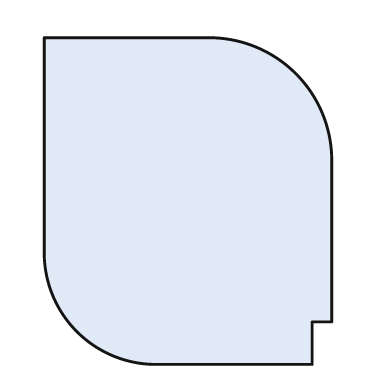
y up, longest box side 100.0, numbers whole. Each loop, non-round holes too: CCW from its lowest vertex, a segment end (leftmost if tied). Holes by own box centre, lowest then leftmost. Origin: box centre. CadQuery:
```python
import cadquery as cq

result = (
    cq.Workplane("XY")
    .moveTo(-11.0, -50.0)
    .lineTo(38.0, -50.0)
    .lineTo(38.0, -37.0)
    .lineTo(44.0, -37.0)
    .lineTo(44.0, 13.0)
    .threePointArc((33.0, 39.0), (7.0, 50.0))
    .lineTo(-44.0, 50.0)
    .lineTo(-44.0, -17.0)
    .threePointArc((-34.0, -40.0), (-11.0, -50.0))
    .close()
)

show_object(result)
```